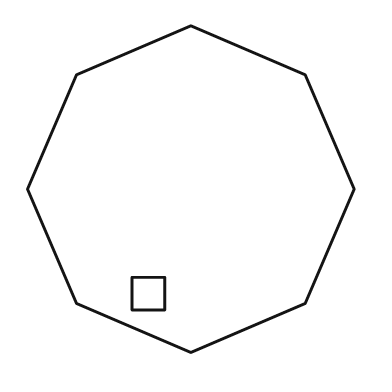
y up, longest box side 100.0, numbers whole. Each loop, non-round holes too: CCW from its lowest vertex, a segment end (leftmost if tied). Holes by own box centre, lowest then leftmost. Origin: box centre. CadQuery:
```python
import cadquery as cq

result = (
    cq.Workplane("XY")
    .moveTo(0.0, -50.0)
    .lineTo(35.0, -35.0)
    .lineTo(50.0, 0.0)
    .lineTo(35.0, 35.0)
    .lineTo(0.0, 50.0)
    .lineTo(-35.0, 35.0)
    .lineTo(-50.0, 0.0)
    .lineTo(-35.0, -35.0)
    .close()
    .moveTo(-18.0, -37.0)
    .lineTo(-8.0, -37.0)
    .lineTo(-8.0, -27.0)
    .lineTo(-18.0, -27.0)
    .close()
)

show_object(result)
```